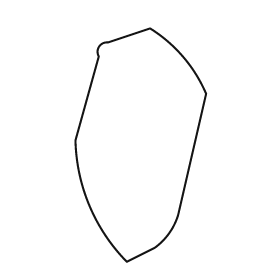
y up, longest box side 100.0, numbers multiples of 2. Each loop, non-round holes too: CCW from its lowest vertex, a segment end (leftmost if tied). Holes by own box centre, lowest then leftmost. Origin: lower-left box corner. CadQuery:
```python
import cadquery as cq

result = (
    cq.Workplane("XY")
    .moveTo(22.0, 0.0)
    .lineTo(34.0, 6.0)
    .threePointArc((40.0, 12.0), (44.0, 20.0))
    .lineTo(56.0, 72.0)
    .threePointArc((46.0, 88.0), (32.0, 100.0))
    .lineTo(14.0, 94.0)
    .threePointArc((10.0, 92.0), (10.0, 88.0))
    .lineTo(0.0, 52.0)
    .threePointArc((6.0, 24.0), (22.0, 0.0))
    .close()
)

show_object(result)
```